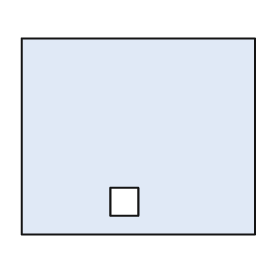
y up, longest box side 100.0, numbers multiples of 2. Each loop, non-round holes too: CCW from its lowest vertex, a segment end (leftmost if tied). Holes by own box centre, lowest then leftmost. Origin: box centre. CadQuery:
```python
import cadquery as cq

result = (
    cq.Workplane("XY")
    .moveTo(-50.0, -42.0)
    .lineTo(50.0, -42.0)
    .lineTo(50.0, 42.0)
    .lineTo(-50.0, 42.0)
    .close()
    .moveTo(-12.0, -34.0)
    .lineTo(0.0, -34.0)
    .lineTo(0.0, -22.0)
    .lineTo(-12.0, -22.0)
    .close()
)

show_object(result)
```